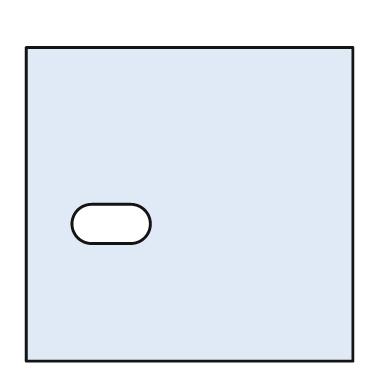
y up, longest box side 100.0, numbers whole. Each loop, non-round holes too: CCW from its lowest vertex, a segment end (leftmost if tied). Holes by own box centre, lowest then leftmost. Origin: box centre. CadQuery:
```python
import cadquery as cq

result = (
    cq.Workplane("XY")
    .moveTo(-50.0, -48.0)
    .lineTo(50.0, -48.0)
    .lineTo(50.0, 48.0)
    .lineTo(-50.0, 48.0)
    .close()
    .moveTo(-30.0, -12.0)
    .lineTo(-18.0, -12.0)
    .threePointArc((-12.0, -6.0), (-18.0, 0.0))
    .lineTo(-30.0, 0.0)
    .threePointArc((-36.0, -6.0), (-30.0, -12.0))
    .close()
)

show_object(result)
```